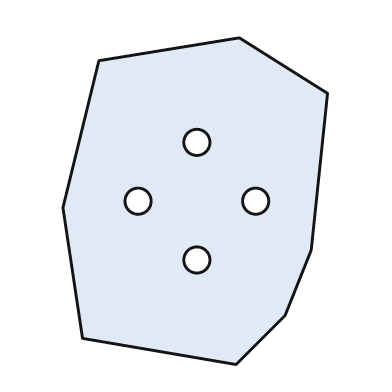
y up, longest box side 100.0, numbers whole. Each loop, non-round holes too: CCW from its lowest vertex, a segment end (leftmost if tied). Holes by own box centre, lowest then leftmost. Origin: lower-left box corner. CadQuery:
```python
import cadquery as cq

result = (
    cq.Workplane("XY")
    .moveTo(53.0, 0.0)
    .lineTo(68.0, 15.0)
    .lineTo(76.0, 35.0)
    .lineTo(81.0, 83.0)
    .lineTo(54.0, 100.0)
    .lineTo(11.0, 93.0)
    .lineTo(0.0, 48.0)
    .lineTo(6.0, 8.0)
    .close()
    .moveTo(41.0, 32.0)
    .circle(4.0)
    .moveTo(23.0, 50.0)
    .circle(4.0)
    .moveTo(59.0, 50.0)
    .circle(4.0)
    .moveTo(41.0, 68.0)
    .circle(4.0)
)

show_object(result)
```